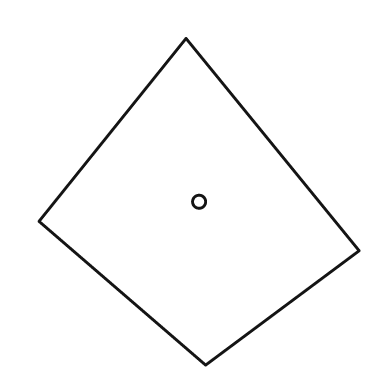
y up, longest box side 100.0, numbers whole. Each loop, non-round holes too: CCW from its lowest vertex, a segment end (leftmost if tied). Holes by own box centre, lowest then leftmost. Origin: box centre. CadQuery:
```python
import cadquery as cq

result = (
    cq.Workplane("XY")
    .moveTo(2.0, -50.0)
    .lineTo(49.0, -15.0)
    .lineTo(-4.0, 50.0)
    .lineTo(-49.0, -6.0)
    .close()
    .moveTo(0.0, 0.0)
    .circle(2.0)
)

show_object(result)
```